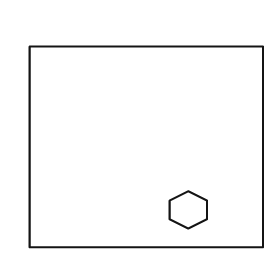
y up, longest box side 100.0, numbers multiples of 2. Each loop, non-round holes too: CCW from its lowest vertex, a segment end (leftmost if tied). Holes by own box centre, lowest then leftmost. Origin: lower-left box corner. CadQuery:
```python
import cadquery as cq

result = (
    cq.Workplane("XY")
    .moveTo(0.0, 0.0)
    .lineTo(100.0, 0.0)
    .lineTo(100.0, 86.0)
    .lineTo(0.0, 86.0)
    .close()
    .moveTo(68.0, 8.0)
    .lineTo(76.0, 12.0)
    .lineTo(76.0, 20.0)
    .lineTo(68.0, 24.0)
    .lineTo(60.0, 20.0)
    .lineTo(60.0, 12.0)
    .close()
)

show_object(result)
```